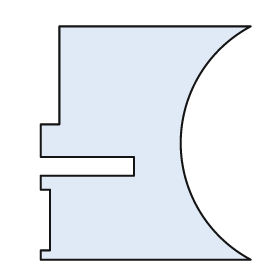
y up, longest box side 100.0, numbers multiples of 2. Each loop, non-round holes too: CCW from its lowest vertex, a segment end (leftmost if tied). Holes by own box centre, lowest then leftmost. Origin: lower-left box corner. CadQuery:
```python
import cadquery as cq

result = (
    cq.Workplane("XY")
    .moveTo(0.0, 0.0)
    .lineTo(90.0, 0.0)
    .threePointArc((60.0, 50.0), (90.0, 100.0))
    .lineTo(8.0, 100.0)
    .lineTo(8.0, 58.0)
    .lineTo(0.0, 58.0)
    .lineTo(0.0, 44.0)
    .lineTo(40.0, 44.0)
    .lineTo(40.0, 36.0)
    .lineTo(0.0, 36.0)
    .lineTo(0.0, 30.0)
    .lineTo(4.0, 30.0)
    .lineTo(4.0, 4.0)
    .lineTo(0.0, 4.0)
    .close()
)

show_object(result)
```